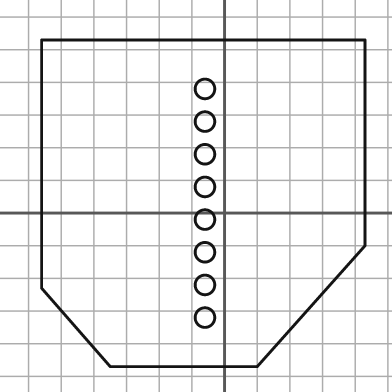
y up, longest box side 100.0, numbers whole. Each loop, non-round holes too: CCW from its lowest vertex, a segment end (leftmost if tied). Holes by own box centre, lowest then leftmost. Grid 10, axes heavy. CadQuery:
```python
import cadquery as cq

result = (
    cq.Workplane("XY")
    .moveTo(-35.0, -47.0)
    .lineTo(10.0, -47.0)
    .lineTo(43.0, -10.0)
    .lineTo(43.0, 53.0)
    .lineTo(-56.0, 53.0)
    .lineTo(-56.0, -23.0)
    .close()
    .moveTo(-6.0, -32.0)
    .circle(3.0)
    .moveTo(-6.0, -22.0)
    .circle(3.0)
    .moveTo(-6.0, -12.0)
    .circle(3.0)
    .moveTo(-6.0, -2.0)
    .circle(3.0)
    .moveTo(-6.0, 8.0)
    .circle(3.0)
    .moveTo(-6.0, 18.0)
    .circle(3.0)
    .moveTo(-6.0, 28.0)
    .circle(3.0)
    .moveTo(-6.0, 38.0)
    .circle(3.0)
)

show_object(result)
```